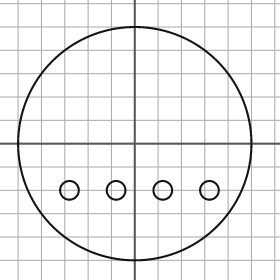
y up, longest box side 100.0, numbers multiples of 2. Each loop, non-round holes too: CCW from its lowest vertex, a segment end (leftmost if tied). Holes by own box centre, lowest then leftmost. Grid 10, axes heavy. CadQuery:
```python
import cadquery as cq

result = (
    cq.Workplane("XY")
    .moveTo(0.0, 0.0)
    .circle(50.0)
    .moveTo(-28.0, -20.0)
    .circle(4.0)
    .moveTo(-8.0, -20.0)
    .circle(4.0)
    .moveTo(12.0, -20.0)
    .circle(4.0)
    .moveTo(32.0, -20.0)
    .circle(4.0)
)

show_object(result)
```